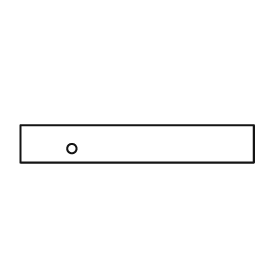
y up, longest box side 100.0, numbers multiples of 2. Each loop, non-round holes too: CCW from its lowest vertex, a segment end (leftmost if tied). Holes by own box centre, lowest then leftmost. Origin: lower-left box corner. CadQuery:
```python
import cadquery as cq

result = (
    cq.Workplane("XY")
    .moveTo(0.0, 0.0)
    .lineTo(100.0, 0.0)
    .lineTo(100.0, 16.0)
    .lineTo(0.0, 16.0)
    .close()
    .moveTo(22.0, 6.0)
    .circle(2.0)
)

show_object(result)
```